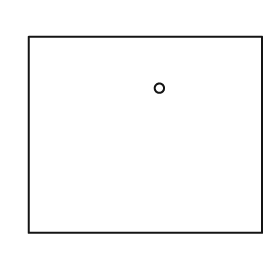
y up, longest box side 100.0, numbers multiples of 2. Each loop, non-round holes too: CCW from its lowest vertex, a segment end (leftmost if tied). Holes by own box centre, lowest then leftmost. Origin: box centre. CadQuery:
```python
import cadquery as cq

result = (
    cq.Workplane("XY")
    .moveTo(-50.0, -42.0)
    .lineTo(50.0, -42.0)
    .lineTo(50.0, 42.0)
    .lineTo(-50.0, 42.0)
    .close()
    .moveTo(6.0, 20.0)
    .circle(2.0)
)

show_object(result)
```